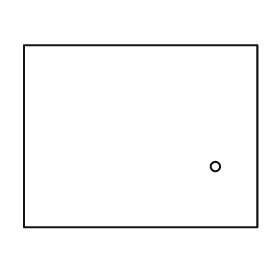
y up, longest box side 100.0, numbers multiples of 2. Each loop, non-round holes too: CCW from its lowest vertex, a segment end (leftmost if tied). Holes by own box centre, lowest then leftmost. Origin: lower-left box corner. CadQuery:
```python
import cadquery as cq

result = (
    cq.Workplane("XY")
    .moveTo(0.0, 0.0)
    .lineTo(100.0, 0.0)
    .lineTo(100.0, 78.0)
    .lineTo(0.0, 78.0)
    .close()
    .moveTo(82.0, 26.0)
    .circle(2.0)
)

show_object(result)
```